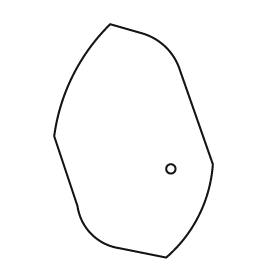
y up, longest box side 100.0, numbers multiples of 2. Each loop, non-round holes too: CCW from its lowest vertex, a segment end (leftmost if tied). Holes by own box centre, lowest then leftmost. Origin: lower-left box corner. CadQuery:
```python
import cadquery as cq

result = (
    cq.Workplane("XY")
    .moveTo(48.0, 0.0)
    .threePointArc((62.0, 18.0), (68.0, 40.0))
    .lineTo(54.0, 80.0)
    .threePointArc((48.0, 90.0), (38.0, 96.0))
    .lineTo(24.0, 100.0)
    .threePointArc((8.0, 78.0), (0.0, 52.0))
    .lineTo(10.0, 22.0)
    .threePointArc((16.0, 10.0), (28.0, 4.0))
    .close()
    .moveTo(50.0, 38.0)
    .circle(2.0)
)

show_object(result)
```